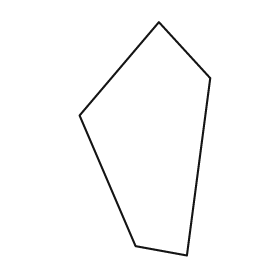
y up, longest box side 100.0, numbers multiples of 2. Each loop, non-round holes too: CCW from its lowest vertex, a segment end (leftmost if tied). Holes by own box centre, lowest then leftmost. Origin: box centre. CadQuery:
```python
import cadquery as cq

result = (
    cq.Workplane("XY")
    .moveTo(18.0, -50.0)
    .lineTo(28.0, 26.0)
    .lineTo(6.0, 50.0)
    .lineTo(-28.0, 10.0)
    .lineTo(-4.0, -46.0)
    .close()
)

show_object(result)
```